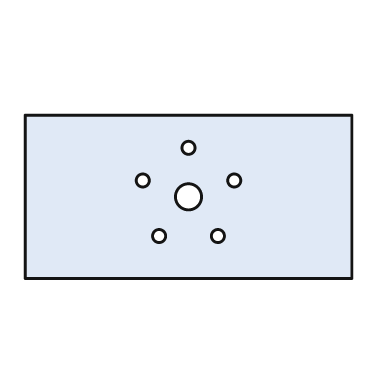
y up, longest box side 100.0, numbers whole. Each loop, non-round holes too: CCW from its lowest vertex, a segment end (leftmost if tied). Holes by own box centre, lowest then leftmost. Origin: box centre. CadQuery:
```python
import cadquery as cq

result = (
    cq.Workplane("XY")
    .moveTo(-50.0, -25.0)
    .lineTo(50.0, -25.0)
    .lineTo(50.0, 25.0)
    .lineTo(-50.0, 25.0)
    .close()
    .moveTo(-9.0, -12.0)
    .circle(2.0)
    .moveTo(9.0, -12.0)
    .circle(2.0)
    .moveTo(0.0, 0.0)
    .circle(4.0)
    .moveTo(-14.0, 5.0)
    .circle(2.0)
    .moveTo(14.0, 5.0)
    .circle(2.0)
    .moveTo(0.0, 15.0)
    .circle(2.0)
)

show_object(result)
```